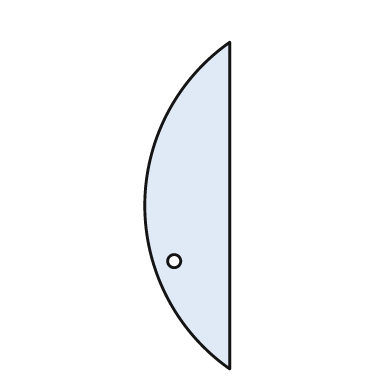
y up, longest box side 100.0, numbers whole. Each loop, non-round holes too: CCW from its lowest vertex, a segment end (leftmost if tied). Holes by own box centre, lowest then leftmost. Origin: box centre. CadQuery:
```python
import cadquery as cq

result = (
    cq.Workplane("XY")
    .moveTo(13.0, -50.0)
    .lineTo(13.0, 50.0)
    .threePointArc((-13.0, 0.0), (13.0, -50.0))
    .close()
    .moveTo(-4.0, -17.0)
    .circle(2.0)
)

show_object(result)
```